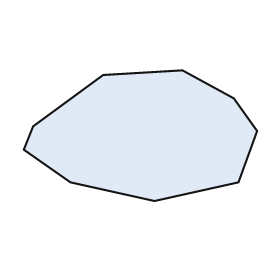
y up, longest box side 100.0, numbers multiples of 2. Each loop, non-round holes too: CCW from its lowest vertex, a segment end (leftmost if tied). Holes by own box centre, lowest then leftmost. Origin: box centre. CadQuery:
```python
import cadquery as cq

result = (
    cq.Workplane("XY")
    .moveTo(6.0, -28.0)
    .lineTo(42.0, -20.0)
    .lineTo(50.0, 2.0)
    .lineTo(40.0, 16.0)
    .lineTo(18.0, 28.0)
    .lineTo(-16.0, 26.0)
    .lineTo(-46.0, 4.0)
    .lineTo(-50.0, -6.0)
    .lineTo(-30.0, -20.0)
    .close()
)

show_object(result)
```